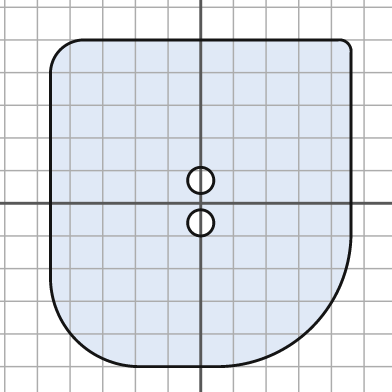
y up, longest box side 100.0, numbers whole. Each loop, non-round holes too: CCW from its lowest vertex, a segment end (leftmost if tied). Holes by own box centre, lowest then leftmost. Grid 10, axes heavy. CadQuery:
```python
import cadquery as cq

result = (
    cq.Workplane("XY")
    .moveTo(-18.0, -50.0)
    .lineTo(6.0, -50.0)
    .threePointArc((34.0, -38.0), (46.0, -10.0))
    .lineTo(46.0, 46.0)
    .threePointArc((45.0, 49.0), (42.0, 50.0))
    .lineTo(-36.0, 50.0)
    .threePointArc((-43.0, 47.0), (-46.0, 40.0))
    .lineTo(-46.0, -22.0)
    .threePointArc((-38.0, -42.0), (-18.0, -50.0))
    .close()
    .moveTo(0.0, -6.0)
    .circle(4.0)
    .moveTo(0.0, 7.0)
    .circle(4.0)
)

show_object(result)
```